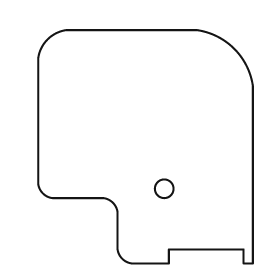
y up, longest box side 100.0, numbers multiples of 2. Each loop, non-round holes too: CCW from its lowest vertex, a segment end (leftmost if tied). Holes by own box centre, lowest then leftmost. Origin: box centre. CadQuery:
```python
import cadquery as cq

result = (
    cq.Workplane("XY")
    .moveTo(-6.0, -50.0)
    .lineTo(10.0, -50.0)
    .lineTo(10.0, -44.0)
    .lineTo(42.0, -44.0)
    .lineTo(42.0, -50.0)
    .lineTo(46.0, -50.0)
    .lineTo(46.0, 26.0)
    .threePointArc((38.0, 42.0), (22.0, 50.0))
    .lineTo(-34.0, 50.0)
    .threePointArc((-42.0, 46.0), (-46.0, 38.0))
    .lineTo(-46.0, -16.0)
    .threePointArc((-44.0, -20.0), (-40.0, -22.0))
    .lineTo(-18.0, -22.0)
    .threePointArc((-14.0, -24.0), (-12.0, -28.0))
    .lineTo(-12.0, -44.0)
    .threePointArc((-10.0, -48.0), (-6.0, -50.0))
    .close()
    .moveTo(8.0, -18.0)
    .circle(4.0)
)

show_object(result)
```